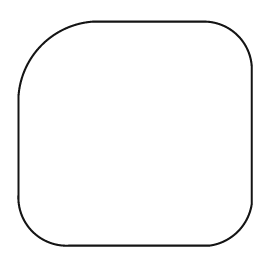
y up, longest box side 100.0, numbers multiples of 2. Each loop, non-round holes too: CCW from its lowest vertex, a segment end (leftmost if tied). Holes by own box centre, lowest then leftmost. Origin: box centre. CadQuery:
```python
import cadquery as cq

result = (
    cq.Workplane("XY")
    .moveTo(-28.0, -48.0)
    .lineTo(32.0, -48.0)
    .threePointArc((44.0, -42.0), (50.0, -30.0))
    .lineTo(50.0, 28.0)
    .threePointArc((44.0, 42.0), (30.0, 48.0))
    .lineTo(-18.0, 48.0)
    .threePointArc((-40.0, 38.0), (-50.0, 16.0))
    .lineTo(-50.0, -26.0)
    .threePointArc((-44.0, -42.0), (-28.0, -48.0))
    .close()
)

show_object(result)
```